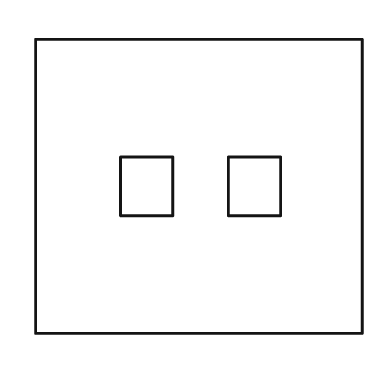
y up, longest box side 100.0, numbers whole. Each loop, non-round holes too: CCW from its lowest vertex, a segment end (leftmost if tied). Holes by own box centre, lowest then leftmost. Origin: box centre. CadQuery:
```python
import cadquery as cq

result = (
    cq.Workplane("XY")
    .moveTo(-50.0, -45.0)
    .lineTo(50.0, -45.0)
    .lineTo(50.0, 45.0)
    .lineTo(-50.0, 45.0)
    .close()
    .moveTo(-24.0, -9.0)
    .lineTo(-8.0, -9.0)
    .lineTo(-8.0, 9.0)
    .lineTo(-24.0, 9.0)
    .close()
    .moveTo(9.0, -9.0)
    .lineTo(25.0, -9.0)
    .lineTo(25.0, 9.0)
    .lineTo(9.0, 9.0)
    .close()
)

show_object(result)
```